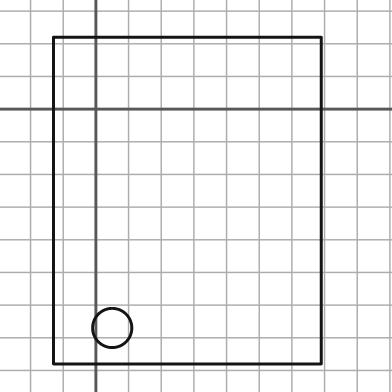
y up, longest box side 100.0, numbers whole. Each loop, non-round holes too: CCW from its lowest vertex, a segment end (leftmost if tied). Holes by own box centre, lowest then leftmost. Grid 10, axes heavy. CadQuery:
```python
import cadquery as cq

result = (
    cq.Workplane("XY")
    .moveTo(-13.0, -78.0)
    .lineTo(69.0, -78.0)
    .lineTo(69.0, 22.0)
    .lineTo(-13.0, 22.0)
    .close()
    .moveTo(5.0, -67.0)
    .circle(6.0)
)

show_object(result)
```